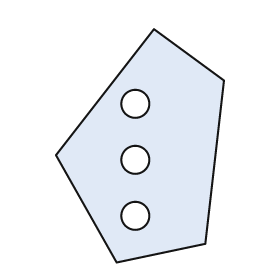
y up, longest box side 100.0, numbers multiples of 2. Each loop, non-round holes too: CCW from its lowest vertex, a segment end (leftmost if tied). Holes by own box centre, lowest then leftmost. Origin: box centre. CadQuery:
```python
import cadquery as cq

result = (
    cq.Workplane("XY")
    .moveTo(-10.0, -50.0)
    .lineTo(28.0, -42.0)
    .lineTo(36.0, 28.0)
    .lineTo(6.0, 50.0)
    .lineTo(-36.0, -4.0)
    .close()
    .moveTo(-2.0, -30.0)
    .circle(6.0)
    .moveTo(-2.0, -6.0)
    .circle(6.0)
    .moveTo(-2.0, 18.0)
    .circle(6.0)
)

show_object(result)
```